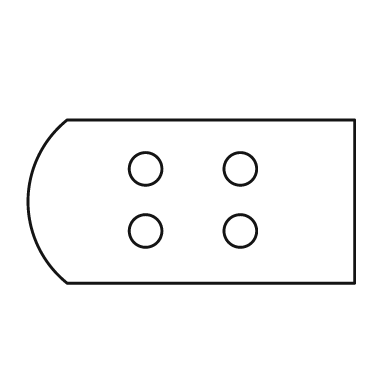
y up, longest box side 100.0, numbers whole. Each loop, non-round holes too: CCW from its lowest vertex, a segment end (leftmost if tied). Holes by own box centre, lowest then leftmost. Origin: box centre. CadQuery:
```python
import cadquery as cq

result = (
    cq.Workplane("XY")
    .moveTo(-38.0, -25.0)
    .lineTo(50.0, -25.0)
    .lineTo(50.0, 25.0)
    .lineTo(-38.0, 25.0)
    .threePointArc((-50.0, 0.0), (-38.0, -25.0))
    .close()
    .moveTo(-14.0, -9.0)
    .circle(5.0)
    .moveTo(15.0, -9.0)
    .circle(5.0)
    .moveTo(-14.0, 10.0)
    .circle(5.0)
    .moveTo(15.0, 10.0)
    .circle(5.0)
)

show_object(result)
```